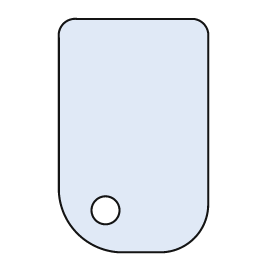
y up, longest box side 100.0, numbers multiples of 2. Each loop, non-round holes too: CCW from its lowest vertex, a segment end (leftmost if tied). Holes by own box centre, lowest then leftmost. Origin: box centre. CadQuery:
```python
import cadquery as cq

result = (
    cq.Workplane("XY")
    .moveTo(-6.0, -50.0)
    .lineTo(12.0, -50.0)
    .threePointArc((26.0, -44.0), (32.0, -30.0))
    .lineTo(32.0, 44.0)
    .threePointArc((30.0, 48.0), (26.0, 50.0))
    .lineTo(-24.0, 50.0)
    .threePointArc((-30.0, 48.0), (-32.0, 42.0))
    .lineTo(-32.0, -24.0)
    .threePointArc((-24.0, -42.0), (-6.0, -50.0))
    .close()
    .moveTo(-12.0, -32.0)
    .circle(6.0)
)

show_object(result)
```